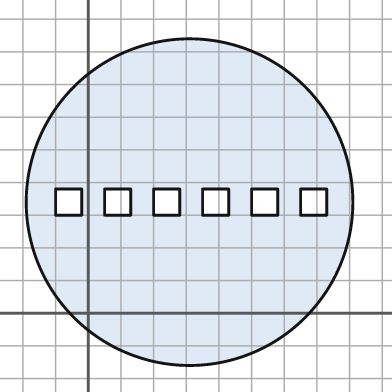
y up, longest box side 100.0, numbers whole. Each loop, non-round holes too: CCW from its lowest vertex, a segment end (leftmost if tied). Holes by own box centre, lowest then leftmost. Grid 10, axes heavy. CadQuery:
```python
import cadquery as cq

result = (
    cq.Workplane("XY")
    .moveTo(31.0, 34.0)
    .circle(50.0)
    .moveTo(-10.0, 30.0)
    .lineTo(-2.0, 30.0)
    .lineTo(-2.0, 38.0)
    .lineTo(-10.0, 38.0)
    .close()
    .moveTo(5.0, 30.0)
    .lineTo(13.0, 30.0)
    .lineTo(13.0, 38.0)
    .lineTo(5.0, 38.0)
    .close()
    .moveTo(20.0, 30.0)
    .lineTo(28.0, 30.0)
    .lineTo(28.0, 38.0)
    .lineTo(20.0, 38.0)
    .close()
    .moveTo(35.0, 30.0)
    .lineTo(43.0, 30.0)
    .lineTo(43.0, 38.0)
    .lineTo(35.0, 38.0)
    .close()
    .moveTo(50.0, 30.0)
    .lineTo(58.0, 30.0)
    .lineTo(58.0, 38.0)
    .lineTo(50.0, 38.0)
    .close()
    .moveTo(65.0, 30.0)
    .lineTo(73.0, 30.0)
    .lineTo(73.0, 38.0)
    .lineTo(65.0, 38.0)
    .close()
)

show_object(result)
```